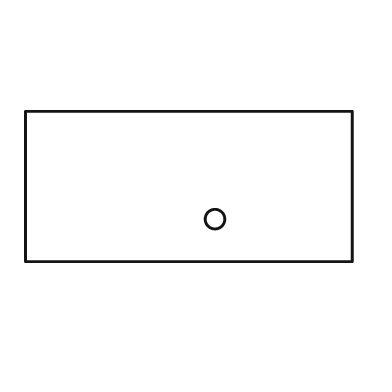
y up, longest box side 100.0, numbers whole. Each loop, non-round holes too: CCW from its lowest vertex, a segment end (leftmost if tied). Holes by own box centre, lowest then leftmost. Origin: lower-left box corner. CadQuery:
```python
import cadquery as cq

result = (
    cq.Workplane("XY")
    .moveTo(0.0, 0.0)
    .lineTo(100.0, 0.0)
    .lineTo(100.0, 46.0)
    .lineTo(0.0, 46.0)
    .close()
    .moveTo(58.0, 13.0)
    .circle(3.0)
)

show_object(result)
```